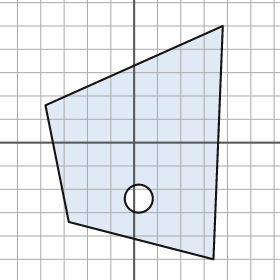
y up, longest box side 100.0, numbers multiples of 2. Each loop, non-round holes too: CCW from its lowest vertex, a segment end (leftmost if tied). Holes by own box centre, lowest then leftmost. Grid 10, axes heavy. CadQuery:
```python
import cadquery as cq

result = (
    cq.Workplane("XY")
    .moveTo(34.0, -50.0)
    .lineTo(38.0, 50.0)
    .lineTo(-38.0, 16.0)
    .lineTo(-28.0, -34.0)
    .close()
    .moveTo(2.0, -24.0)
    .circle(6.0)
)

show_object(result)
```